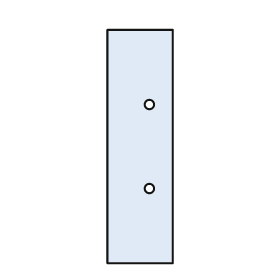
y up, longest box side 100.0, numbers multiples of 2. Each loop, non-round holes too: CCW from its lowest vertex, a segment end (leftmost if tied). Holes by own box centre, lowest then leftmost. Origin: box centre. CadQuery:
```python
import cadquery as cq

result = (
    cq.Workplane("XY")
    .moveTo(-14.0, -50.0)
    .lineTo(14.0, -50.0)
    .lineTo(14.0, 50.0)
    .lineTo(-14.0, 50.0)
    .close()
    .moveTo(4.0, -18.0)
    .circle(2.0)
    .moveTo(4.0, 18.0)
    .circle(2.0)
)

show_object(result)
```